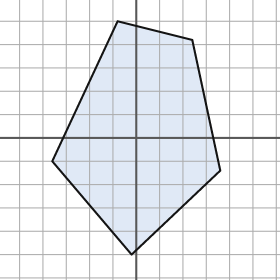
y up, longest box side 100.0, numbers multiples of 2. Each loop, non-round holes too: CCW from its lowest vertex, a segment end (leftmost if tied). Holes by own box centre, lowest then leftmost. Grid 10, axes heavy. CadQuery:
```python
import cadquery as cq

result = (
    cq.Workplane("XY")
    .moveTo(-2.0, -50.0)
    .lineTo(36.0, -14.0)
    .lineTo(24.0, 42.0)
    .lineTo(-8.0, 50.0)
    .lineTo(-36.0, -10.0)
    .close()
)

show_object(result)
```